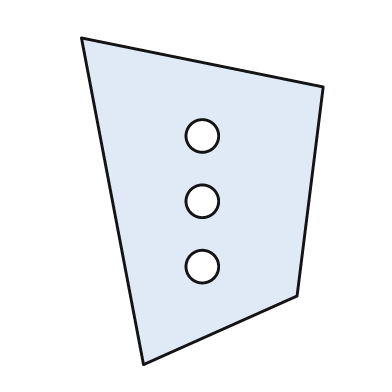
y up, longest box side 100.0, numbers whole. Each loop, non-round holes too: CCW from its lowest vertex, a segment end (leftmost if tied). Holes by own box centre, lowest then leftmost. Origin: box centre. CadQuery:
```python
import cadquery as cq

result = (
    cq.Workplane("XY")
    .moveTo(-18.0, -50.0)
    .lineTo(29.0, -29.0)
    .lineTo(37.0, 35.0)
    .lineTo(-37.0, 50.0)
    .close()
    .moveTo(0.0, -20.0)
    .circle(5.0)
    .moveTo(0.0, 0.0)
    .circle(5.0)
    .moveTo(0.0, 20.0)
    .circle(5.0)
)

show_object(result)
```